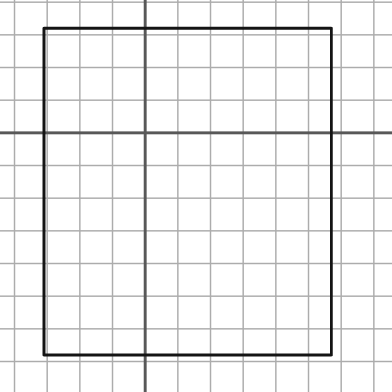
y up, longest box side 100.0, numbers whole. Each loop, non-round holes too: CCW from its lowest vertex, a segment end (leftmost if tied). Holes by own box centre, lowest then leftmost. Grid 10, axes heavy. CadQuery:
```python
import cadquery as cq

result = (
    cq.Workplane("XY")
    .moveTo(-31.0, -68.0)
    .lineTo(57.0, -68.0)
    .lineTo(57.0, 32.0)
    .lineTo(-31.0, 32.0)
    .close()
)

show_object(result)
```